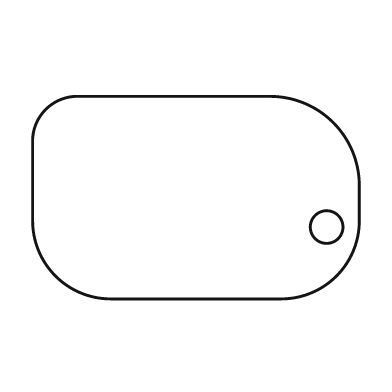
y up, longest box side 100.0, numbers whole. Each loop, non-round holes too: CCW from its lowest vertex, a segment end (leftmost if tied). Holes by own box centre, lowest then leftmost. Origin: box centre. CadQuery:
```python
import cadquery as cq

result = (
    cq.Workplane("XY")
    .moveTo(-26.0, -31.0)
    .lineTo(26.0, -31.0)
    .threePointArc((43.0, -24.0), (50.0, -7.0))
    .lineTo(50.0, 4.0)
    .threePointArc((42.0, 23.0), (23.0, 31.0))
    .lineTo(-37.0, 31.0)
    .threePointArc((-46.0, 27.0), (-50.0, 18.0))
    .lineTo(-50.0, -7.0)
    .threePointArc((-43.0, -24.0), (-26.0, -31.0))
    .close()
    .moveTo(40.0, -9.0)
    .circle(5.0)
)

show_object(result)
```